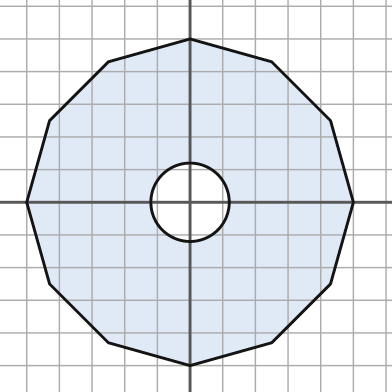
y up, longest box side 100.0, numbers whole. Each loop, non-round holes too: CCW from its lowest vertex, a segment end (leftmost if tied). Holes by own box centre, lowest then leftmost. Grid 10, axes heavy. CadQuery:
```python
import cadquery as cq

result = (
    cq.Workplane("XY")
    .moveTo(0.0, -50.0)
    .lineTo(25.0, -43.0)
    .lineTo(43.0, -25.0)
    .lineTo(50.0, 0.0)
    .lineTo(43.0, 25.0)
    .lineTo(25.0, 43.0)
    .lineTo(0.0, 50.0)
    .lineTo(-25.0, 43.0)
    .lineTo(-43.0, 25.0)
    .lineTo(-50.0, 0.0)
    .lineTo(-43.0, -25.0)
    .lineTo(-25.0, -43.0)
    .close()
    .moveTo(0.0, 0.0)
    .circle(12.0)
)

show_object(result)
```